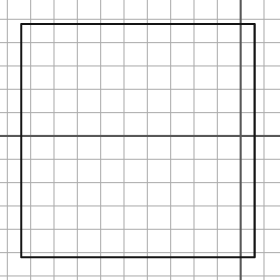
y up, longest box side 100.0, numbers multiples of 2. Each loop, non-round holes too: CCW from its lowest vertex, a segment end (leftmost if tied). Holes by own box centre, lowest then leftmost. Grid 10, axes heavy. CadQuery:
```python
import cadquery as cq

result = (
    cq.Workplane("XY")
    .moveTo(-94.0, -52.0)
    .lineTo(6.0, -52.0)
    .lineTo(6.0, 48.0)
    .lineTo(-94.0, 48.0)
    .close()
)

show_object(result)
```